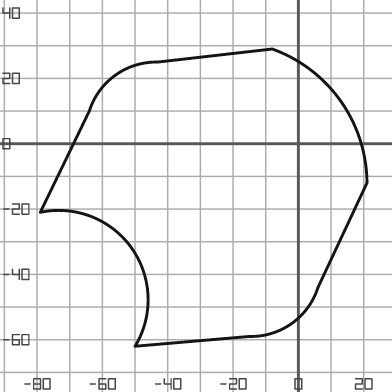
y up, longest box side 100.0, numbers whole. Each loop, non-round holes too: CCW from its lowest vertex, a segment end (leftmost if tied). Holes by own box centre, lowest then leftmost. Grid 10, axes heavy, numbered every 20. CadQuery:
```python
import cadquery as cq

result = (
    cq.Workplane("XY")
    .moveTo(-50.0, -62.0)
    .lineTo(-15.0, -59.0)
    .threePointArc((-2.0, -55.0), (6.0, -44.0))
    .lineTo(21.0, -12.0)
    .threePointArc((13.0, 13.0), (-8.0, 29.0))
    .lineTo(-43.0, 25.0)
    .threePointArc((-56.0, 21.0), (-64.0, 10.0))
    .lineTo(-79.0, -21.0)
    .threePointArc((-51.0, -32.0), (-50.0, -62.0))
    .close()
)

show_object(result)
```